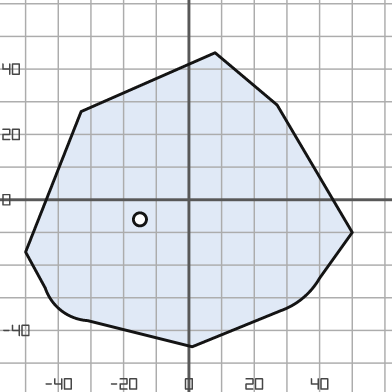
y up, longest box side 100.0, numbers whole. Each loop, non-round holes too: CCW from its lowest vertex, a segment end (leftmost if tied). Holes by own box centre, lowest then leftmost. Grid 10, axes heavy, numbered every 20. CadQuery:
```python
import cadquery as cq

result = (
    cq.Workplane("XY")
    .moveTo(1.0, -45.0)
    .lineTo(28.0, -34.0)
    .threePointArc((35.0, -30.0), (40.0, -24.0))
    .lineTo(50.0, -10.0)
    .lineTo(27.0, 29.0)
    .lineTo(8.0, 45.0)
    .lineTo(-33.0, 27.0)
    .lineTo(-50.0, -16.0)
    .lineTo(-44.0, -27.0)
    .threePointArc((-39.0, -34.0), (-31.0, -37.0))
    .close()
    .moveTo(-15.0, -6.0)
    .circle(2.0)
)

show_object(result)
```